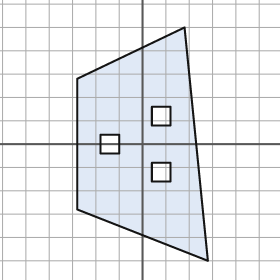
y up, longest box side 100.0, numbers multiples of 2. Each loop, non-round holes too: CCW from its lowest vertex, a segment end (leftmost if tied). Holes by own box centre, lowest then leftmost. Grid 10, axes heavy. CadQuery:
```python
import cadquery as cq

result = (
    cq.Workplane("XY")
    .moveTo(28.0, -50.0)
    .lineTo(18.0, 50.0)
    .lineTo(-28.0, 28.0)
    .lineTo(-28.0, -28.0)
    .close()
    .moveTo(4.0, -16.0)
    .lineTo(12.0, -16.0)
    .lineTo(12.0, -8.0)
    .lineTo(4.0, -8.0)
    .close()
    .moveTo(-18.0, -4.0)
    .lineTo(-10.0, -4.0)
    .lineTo(-10.0, 4.0)
    .lineTo(-18.0, 4.0)
    .close()
    .moveTo(4.0, 8.0)
    .lineTo(12.0, 8.0)
    .lineTo(12.0, 16.0)
    .lineTo(4.0, 16.0)
    .close()
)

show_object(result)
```